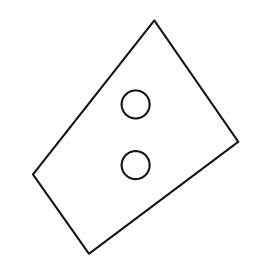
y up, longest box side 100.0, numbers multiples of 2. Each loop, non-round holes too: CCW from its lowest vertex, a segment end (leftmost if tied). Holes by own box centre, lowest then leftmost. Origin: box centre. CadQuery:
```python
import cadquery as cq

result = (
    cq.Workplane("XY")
    .moveTo(-20.0, -50.0)
    .lineTo(44.0, -2.0)
    .lineTo(8.0, 50.0)
    .lineTo(-44.0, -16.0)
    .close()
    .moveTo(0.0, -12.0)
    .circle(6.0)
    .moveTo(0.0, 14.0)
    .circle(6.0)
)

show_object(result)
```